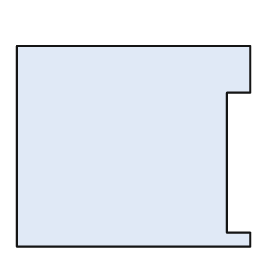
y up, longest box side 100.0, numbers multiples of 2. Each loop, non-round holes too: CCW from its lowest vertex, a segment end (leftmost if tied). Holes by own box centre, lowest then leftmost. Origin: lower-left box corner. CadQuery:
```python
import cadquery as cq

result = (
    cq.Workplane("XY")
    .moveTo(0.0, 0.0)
    .lineTo(100.0, 0.0)
    .lineTo(100.0, 6.0)
    .lineTo(90.0, 6.0)
    .lineTo(90.0, 66.0)
    .lineTo(100.0, 66.0)
    .lineTo(100.0, 86.0)
    .lineTo(0.0, 86.0)
    .close()
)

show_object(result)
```